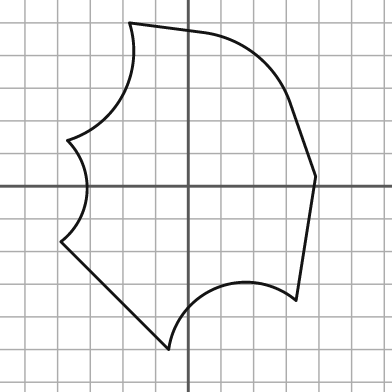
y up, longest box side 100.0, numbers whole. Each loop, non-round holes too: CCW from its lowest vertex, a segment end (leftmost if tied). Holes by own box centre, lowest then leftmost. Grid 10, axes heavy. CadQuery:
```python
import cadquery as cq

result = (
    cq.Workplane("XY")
    .moveTo(-6.0, -50.0)
    .threePointArc((9.0, -31.0), (33.0, -35.0))
    .lineTo(39.0, 3.0)
    .lineTo(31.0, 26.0)
    .threePointArc((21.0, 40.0), (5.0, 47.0))
    .lineTo(-18.0, 50.0)
    .threePointArc((-20.0, 28.0), (-37.0, 14.0))
    .threePointArc((-31.0, -2.0), (-39.0, -17.0))
    .close()
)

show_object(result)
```